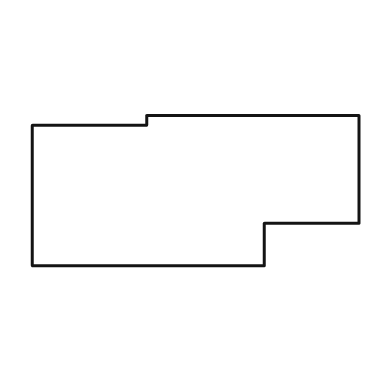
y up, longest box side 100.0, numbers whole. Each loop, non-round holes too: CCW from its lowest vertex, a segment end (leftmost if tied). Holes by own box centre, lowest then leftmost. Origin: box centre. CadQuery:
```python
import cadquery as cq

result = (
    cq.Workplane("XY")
    .moveTo(-50.0, -23.0)
    .lineTo(21.0, -23.0)
    .lineTo(21.0, -10.0)
    .lineTo(50.0, -10.0)
    .lineTo(50.0, 23.0)
    .lineTo(-15.0, 23.0)
    .lineTo(-15.0, 20.0)
    .lineTo(-50.0, 20.0)
    .close()
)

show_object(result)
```